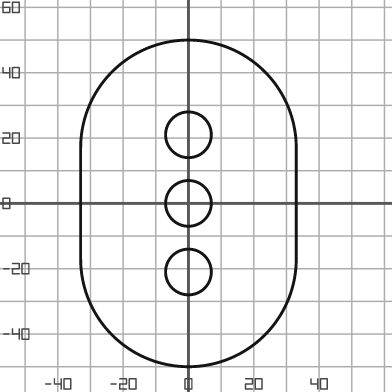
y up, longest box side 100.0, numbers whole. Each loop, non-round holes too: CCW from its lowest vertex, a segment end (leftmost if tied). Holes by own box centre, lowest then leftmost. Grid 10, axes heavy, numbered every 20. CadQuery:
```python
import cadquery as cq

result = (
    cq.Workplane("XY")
    .moveTo(-33.0, -17.0)
    .threePointArc((0.0, -50.0), (33.0, -17.0))
    .lineTo(33.0, 17.0)
    .threePointArc((0.0, 50.0), (-33.0, 17.0))
    .close()
    .moveTo(0.0, -21.0)
    .circle(7.0)
    .moveTo(0.0, 0.0)
    .circle(7.0)
    .moveTo(0.0, 21.0)
    .circle(7.0)
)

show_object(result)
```